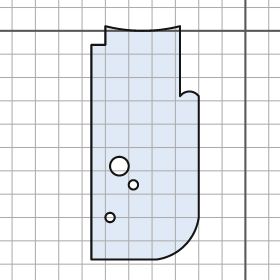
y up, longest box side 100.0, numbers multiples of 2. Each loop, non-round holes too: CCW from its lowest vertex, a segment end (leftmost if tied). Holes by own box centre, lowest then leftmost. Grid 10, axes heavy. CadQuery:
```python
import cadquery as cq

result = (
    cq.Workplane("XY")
    .moveTo(-66.0, -98.0)
    .lineTo(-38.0, -98.0)
    .threePointArc((-26.0, -92.0), (-20.0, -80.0))
    .lineTo(-20.0, -28.0)
    .threePointArc((-24.0, -26.0), (-28.0, -28.0))
    .lineTo(-28.0, 2.0)
    .threePointArc((-44.0, 0.0), (-60.0, 2.0))
    .lineTo(-60.0, -6.0)
    .lineTo(-66.0, -6.0)
    .close()
    .moveTo(-58.0, -80.0)
    .circle(2.0)
    .moveTo(-48.0, -66.0)
    .circle(2.0)
    .moveTo(-54.0, -58.0)
    .circle(4.0)
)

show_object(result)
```